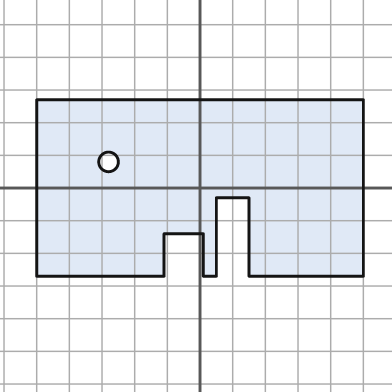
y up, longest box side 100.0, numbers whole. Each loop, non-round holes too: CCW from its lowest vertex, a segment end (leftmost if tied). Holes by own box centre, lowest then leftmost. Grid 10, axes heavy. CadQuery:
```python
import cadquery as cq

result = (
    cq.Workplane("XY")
    .moveTo(-50.0, -27.0)
    .lineTo(-11.0, -27.0)
    .lineTo(-11.0, -14.0)
    .lineTo(1.0, -14.0)
    .lineTo(1.0, -27.0)
    .lineTo(5.0, -27.0)
    .lineTo(5.0, -3.0)
    .lineTo(15.0, -3.0)
    .lineTo(15.0, -27.0)
    .lineTo(50.0, -27.0)
    .lineTo(50.0, 27.0)
    .lineTo(-50.0, 27.0)
    .close()
    .moveTo(-28.0, 8.0)
    .circle(3.0)
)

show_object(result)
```